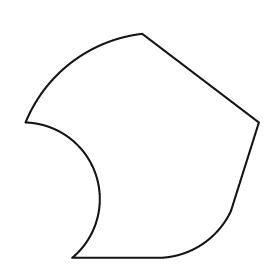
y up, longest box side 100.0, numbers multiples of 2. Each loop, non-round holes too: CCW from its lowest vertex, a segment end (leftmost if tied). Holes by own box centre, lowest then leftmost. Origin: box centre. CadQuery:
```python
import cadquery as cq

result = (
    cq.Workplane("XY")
    .moveTo(-30.0, -48.0)
    .lineTo(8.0, -48.0)
    .threePointArc((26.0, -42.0), (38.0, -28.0))
    .lineTo(50.0, 10.0)
    .lineTo(0.0, 48.0)
    .threePointArc((-30.0, 36.0), (-50.0, 10.0))
    .threePointArc((-20.0, -12.0), (-30.0, -48.0))
    .close()
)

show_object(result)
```